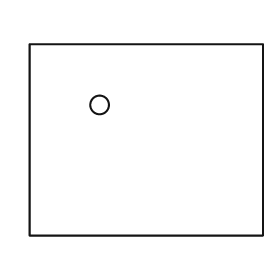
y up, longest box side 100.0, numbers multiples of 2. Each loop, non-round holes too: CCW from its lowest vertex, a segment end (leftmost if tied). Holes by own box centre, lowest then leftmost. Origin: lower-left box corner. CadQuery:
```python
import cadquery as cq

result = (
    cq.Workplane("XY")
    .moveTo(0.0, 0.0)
    .lineTo(100.0, 0.0)
    .lineTo(100.0, 82.0)
    .lineTo(0.0, 82.0)
    .close()
    .moveTo(30.0, 56.0)
    .circle(4.0)
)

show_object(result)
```